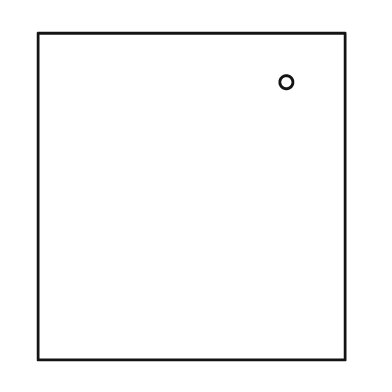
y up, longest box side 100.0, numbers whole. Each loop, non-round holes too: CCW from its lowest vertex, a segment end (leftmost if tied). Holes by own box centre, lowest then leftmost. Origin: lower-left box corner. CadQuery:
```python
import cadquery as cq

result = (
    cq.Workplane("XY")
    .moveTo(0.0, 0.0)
    .lineTo(94.0, 0.0)
    .lineTo(94.0, 100.0)
    .lineTo(0.0, 100.0)
    .close()
    .moveTo(76.0, 85.0)
    .circle(2.0)
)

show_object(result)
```